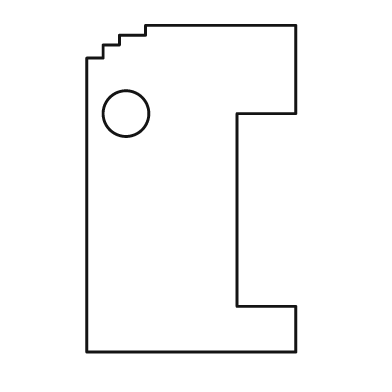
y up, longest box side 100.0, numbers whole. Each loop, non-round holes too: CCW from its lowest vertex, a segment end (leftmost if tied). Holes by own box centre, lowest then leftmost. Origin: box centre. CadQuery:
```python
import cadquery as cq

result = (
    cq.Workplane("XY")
    .moveTo(-32.0, -50.0)
    .lineTo(32.0, -50.0)
    .lineTo(32.0, -36.0)
    .lineTo(14.0, -36.0)
    .lineTo(14.0, 23.0)
    .lineTo(32.0, 23.0)
    .lineTo(32.0, 50.0)
    .lineTo(-14.0, 50.0)
    .lineTo(-14.0, 47.0)
    .lineTo(-22.0, 47.0)
    .lineTo(-22.0, 44.0)
    .lineTo(-27.0, 44.0)
    .lineTo(-27.0, 40.0)
    .lineTo(-32.0, 40.0)
    .close()
    .moveTo(-20.0, 23.0)
    .circle(7.0)
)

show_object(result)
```